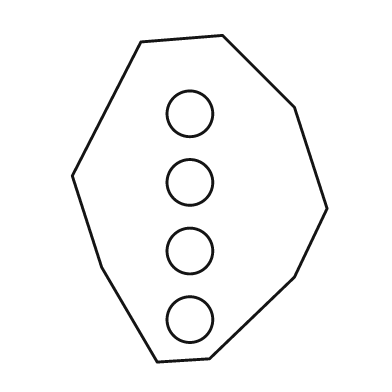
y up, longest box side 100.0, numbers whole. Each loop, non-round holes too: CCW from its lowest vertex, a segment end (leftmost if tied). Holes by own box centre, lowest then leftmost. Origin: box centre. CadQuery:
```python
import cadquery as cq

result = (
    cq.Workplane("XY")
    .moveTo(-13.0, -50.0)
    .lineTo(3.0, -49.0)
    .lineTo(29.0, -24.0)
    .lineTo(39.0, -3.0)
    .lineTo(29.0, 28.0)
    .lineTo(7.0, 50.0)
    .lineTo(-18.0, 48.0)
    .lineTo(-39.0, 7.0)
    .lineTo(-30.0, -21.0)
    .close()
    .moveTo(-3.0, -37.0)
    .circle(7.0)
    .moveTo(-3.0, -16.0)
    .circle(7.0)
    .moveTo(-3.0, 5.0)
    .circle(7.0)
    .moveTo(-3.0, 26.0)
    .circle(7.0)
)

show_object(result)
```